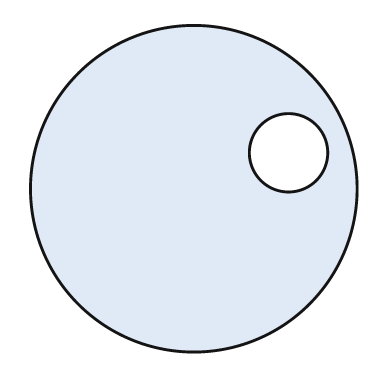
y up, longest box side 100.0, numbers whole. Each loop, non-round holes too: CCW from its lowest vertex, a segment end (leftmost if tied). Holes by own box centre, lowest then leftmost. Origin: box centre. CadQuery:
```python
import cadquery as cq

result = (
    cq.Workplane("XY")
    .moveTo(0.0, 0.0)
    .circle(50.0)
    .moveTo(29.0, 11.0)
    .circle(12.0)
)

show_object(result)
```